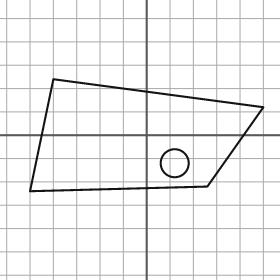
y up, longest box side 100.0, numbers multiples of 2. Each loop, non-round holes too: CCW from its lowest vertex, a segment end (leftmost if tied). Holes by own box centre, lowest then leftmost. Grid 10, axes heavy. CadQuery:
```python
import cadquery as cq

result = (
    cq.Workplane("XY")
    .moveTo(-50.0, -24.0)
    .lineTo(26.0, -22.0)
    .lineTo(50.0, 12.0)
    .lineTo(-40.0, 24.0)
    .close()
    .moveTo(12.0, -12.0)
    .circle(6.0)
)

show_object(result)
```